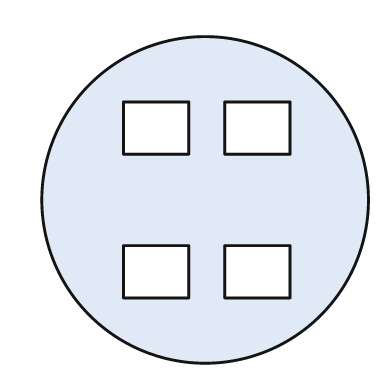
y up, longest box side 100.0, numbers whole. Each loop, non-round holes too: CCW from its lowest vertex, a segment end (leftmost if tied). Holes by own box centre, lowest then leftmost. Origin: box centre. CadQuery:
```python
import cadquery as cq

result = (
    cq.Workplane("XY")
    .moveTo(0.0, 0.0)
    .circle(50.0)
    .moveTo(-25.0, -30.0)
    .lineTo(-5.0, -30.0)
    .lineTo(-5.0, -14.0)
    .lineTo(-25.0, -14.0)
    .close()
    .moveTo(6.0, -30.0)
    .lineTo(26.0, -30.0)
    .lineTo(26.0, -14.0)
    .lineTo(6.0, -14.0)
    .close()
    .moveTo(-25.0, 14.0)
    .lineTo(-5.0, 14.0)
    .lineTo(-5.0, 30.0)
    .lineTo(-25.0, 30.0)
    .close()
    .moveTo(6.0, 14.0)
    .lineTo(26.0, 14.0)
    .lineTo(26.0, 30.0)
    .lineTo(6.0, 30.0)
    .close()
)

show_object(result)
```